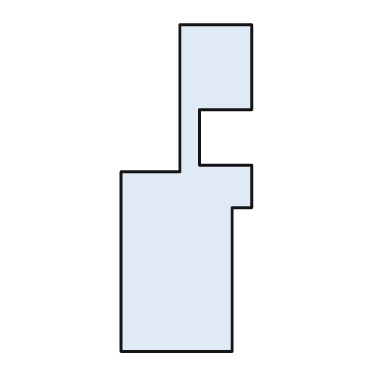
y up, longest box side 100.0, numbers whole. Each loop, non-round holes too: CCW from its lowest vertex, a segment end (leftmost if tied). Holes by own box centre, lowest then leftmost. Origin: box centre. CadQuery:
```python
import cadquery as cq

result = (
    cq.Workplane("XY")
    .moveTo(-20.0, -50.0)
    .lineTo(14.0, -50.0)
    .lineTo(14.0, -6.0)
    .lineTo(20.0, -6.0)
    .lineTo(20.0, 7.0)
    .lineTo(4.0, 7.0)
    .lineTo(4.0, 24.0)
    .lineTo(20.0, 24.0)
    .lineTo(20.0, 50.0)
    .lineTo(-2.0, 50.0)
    .lineTo(-2.0, 5.0)
    .lineTo(-20.0, 5.0)
    .close()
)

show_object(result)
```